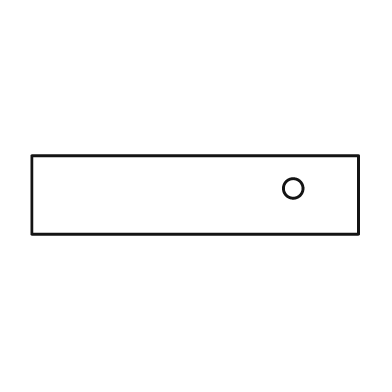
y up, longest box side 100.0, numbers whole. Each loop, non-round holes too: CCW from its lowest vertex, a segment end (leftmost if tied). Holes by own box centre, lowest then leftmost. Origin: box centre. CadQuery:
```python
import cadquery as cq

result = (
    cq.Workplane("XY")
    .moveTo(-50.0, -12.0)
    .lineTo(50.0, -12.0)
    .lineTo(50.0, 12.0)
    .lineTo(-50.0, 12.0)
    .close()
    .moveTo(30.0, 2.0)
    .circle(3.0)
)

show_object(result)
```